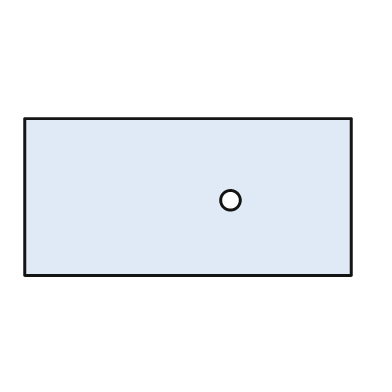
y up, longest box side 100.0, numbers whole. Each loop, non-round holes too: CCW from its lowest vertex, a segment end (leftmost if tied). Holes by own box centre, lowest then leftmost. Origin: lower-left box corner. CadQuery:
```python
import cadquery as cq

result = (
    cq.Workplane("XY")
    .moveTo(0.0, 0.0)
    .lineTo(100.0, 0.0)
    .lineTo(100.0, 48.0)
    .lineTo(0.0, 48.0)
    .close()
    .moveTo(63.0, 23.0)
    .circle(3.0)
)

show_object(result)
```